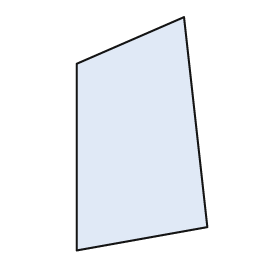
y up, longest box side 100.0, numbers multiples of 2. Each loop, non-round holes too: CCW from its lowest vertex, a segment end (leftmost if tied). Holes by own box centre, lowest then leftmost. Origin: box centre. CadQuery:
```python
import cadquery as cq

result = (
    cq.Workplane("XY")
    .moveTo(-28.0, -50.0)
    .lineTo(28.0, -40.0)
    .lineTo(18.0, 50.0)
    .lineTo(-28.0, 30.0)
    .close()
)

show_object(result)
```